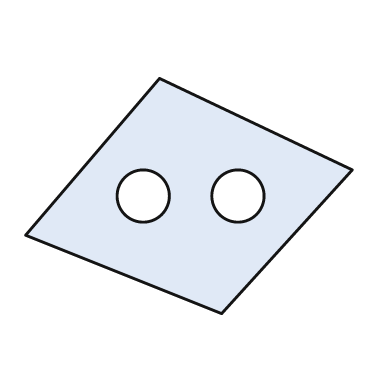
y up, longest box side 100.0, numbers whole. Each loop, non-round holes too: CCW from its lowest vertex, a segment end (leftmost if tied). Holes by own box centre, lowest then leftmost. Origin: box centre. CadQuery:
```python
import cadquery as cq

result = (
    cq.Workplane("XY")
    .moveTo(10.0, -36.0)
    .lineTo(50.0, 8.0)
    .lineTo(-9.0, 36.0)
    .lineTo(-50.0, -12.0)
    .close()
    .moveTo(-14.0, 0.0)
    .circle(8.0)
    .moveTo(15.0, 0.0)
    .circle(8.0)
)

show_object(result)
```